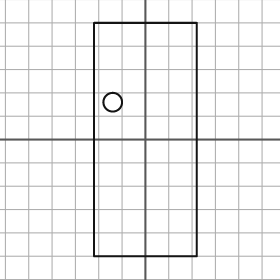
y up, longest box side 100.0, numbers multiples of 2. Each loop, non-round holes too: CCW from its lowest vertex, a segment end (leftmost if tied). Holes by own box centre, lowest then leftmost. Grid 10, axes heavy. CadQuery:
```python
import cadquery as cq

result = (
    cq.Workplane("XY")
    .moveTo(-22.0, -50.0)
    .lineTo(22.0, -50.0)
    .lineTo(22.0, 50.0)
    .lineTo(-22.0, 50.0)
    .close()
    .moveTo(-14.0, 16.0)
    .circle(4.0)
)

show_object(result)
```